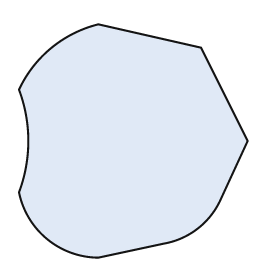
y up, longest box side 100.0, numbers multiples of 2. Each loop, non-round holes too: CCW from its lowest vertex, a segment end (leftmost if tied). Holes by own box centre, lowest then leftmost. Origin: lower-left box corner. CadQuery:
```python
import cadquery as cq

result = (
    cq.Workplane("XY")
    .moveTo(34.0, 0.0)
    .lineTo(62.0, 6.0)
    .threePointArc((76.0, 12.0), (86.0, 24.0))
    .lineTo(98.0, 50.0)
    .lineTo(78.0, 90.0)
    .lineTo(34.0, 100.0)
    .threePointArc((14.0, 90.0), (0.0, 72.0))
    .threePointArc((4.0, 50.0), (0.0, 28.0))
    .threePointArc((12.0, 8.0), (34.0, 0.0))
    .close()
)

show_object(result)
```